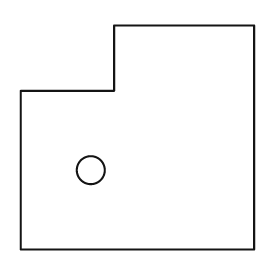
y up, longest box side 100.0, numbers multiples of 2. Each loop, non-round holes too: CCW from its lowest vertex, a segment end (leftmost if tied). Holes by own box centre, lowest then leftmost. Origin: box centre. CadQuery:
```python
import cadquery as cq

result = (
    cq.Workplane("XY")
    .moveTo(-50.0, -48.0)
    .lineTo(50.0, -48.0)
    .lineTo(50.0, 48.0)
    .lineTo(-10.0, 48.0)
    .lineTo(-10.0, 20.0)
    .lineTo(-50.0, 20.0)
    .close()
    .moveTo(-20.0, -14.0)
    .circle(6.0)
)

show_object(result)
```